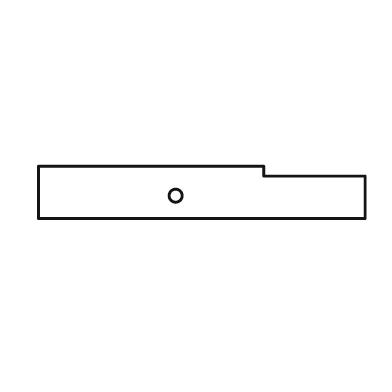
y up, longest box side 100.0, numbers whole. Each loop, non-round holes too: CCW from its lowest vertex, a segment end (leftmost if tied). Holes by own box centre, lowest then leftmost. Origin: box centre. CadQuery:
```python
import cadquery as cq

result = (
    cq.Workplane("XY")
    .moveTo(-50.0, -8.0)
    .lineTo(50.0, -8.0)
    .lineTo(50.0, 5.0)
    .lineTo(19.0, 5.0)
    .lineTo(19.0, 8.0)
    .lineTo(-50.0, 8.0)
    .close()
    .moveTo(-8.0, -1.0)
    .circle(2.0)
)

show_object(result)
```